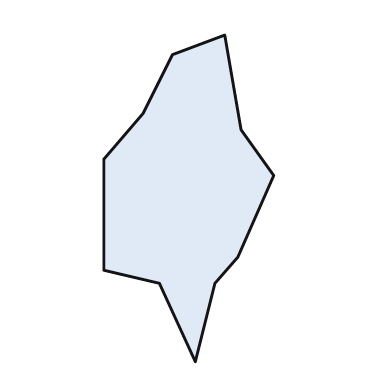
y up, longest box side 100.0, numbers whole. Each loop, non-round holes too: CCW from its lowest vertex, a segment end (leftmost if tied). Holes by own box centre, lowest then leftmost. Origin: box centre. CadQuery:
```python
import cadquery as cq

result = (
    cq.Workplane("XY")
    .moveTo(2.0, -50.0)
    .lineTo(8.0, -26.0)
    .lineTo(15.0, -18.0)
    .lineTo(26.0, 7.0)
    .lineTo(16.0, 21.0)
    .lineTo(11.0, 50.0)
    .lineTo(-5.0, 44.0)
    .lineTo(-14.0, 26.0)
    .lineTo(-26.0, 12.0)
    .lineTo(-26.0, -22.0)
    .lineTo(-9.0, -26.0)
    .close()
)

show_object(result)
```